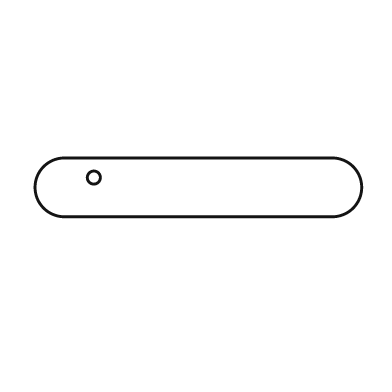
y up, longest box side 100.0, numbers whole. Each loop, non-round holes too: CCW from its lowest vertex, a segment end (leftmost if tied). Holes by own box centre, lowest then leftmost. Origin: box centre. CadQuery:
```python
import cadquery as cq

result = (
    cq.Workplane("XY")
    .moveTo(-41.0, -9.0)
    .lineTo(41.0, -9.0)
    .threePointArc((50.0, 0.0), (41.0, 9.0))
    .lineTo(-41.0, 9.0)
    .threePointArc((-50.0, 0.0), (-41.0, -9.0))
    .close()
    .moveTo(-32.0, 3.0)
    .circle(2.0)
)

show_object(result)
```